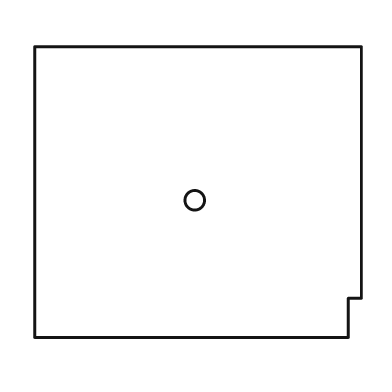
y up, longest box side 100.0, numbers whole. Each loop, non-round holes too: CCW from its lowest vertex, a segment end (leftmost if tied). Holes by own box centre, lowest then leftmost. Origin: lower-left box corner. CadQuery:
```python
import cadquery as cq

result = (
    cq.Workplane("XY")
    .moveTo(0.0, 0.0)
    .lineTo(96.0, 0.0)
    .lineTo(96.0, 12.0)
    .lineTo(100.0, 12.0)
    .lineTo(100.0, 89.0)
    .lineTo(0.0, 89.0)
    .close()
    .moveTo(49.0, 42.0)
    .circle(3.0)
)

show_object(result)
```